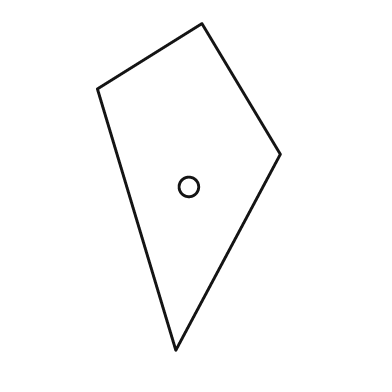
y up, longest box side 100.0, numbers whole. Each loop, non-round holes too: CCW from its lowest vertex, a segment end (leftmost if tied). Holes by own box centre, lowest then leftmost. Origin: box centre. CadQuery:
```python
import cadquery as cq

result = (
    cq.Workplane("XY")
    .moveTo(-4.0, -50.0)
    .lineTo(28.0, 10.0)
    .lineTo(4.0, 50.0)
    .lineTo(-28.0, 30.0)
    .close()
    .moveTo(0.0, 0.0)
    .circle(3.0)
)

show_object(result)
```